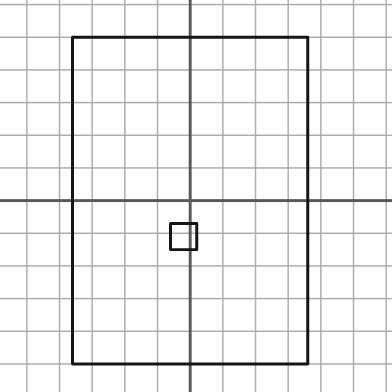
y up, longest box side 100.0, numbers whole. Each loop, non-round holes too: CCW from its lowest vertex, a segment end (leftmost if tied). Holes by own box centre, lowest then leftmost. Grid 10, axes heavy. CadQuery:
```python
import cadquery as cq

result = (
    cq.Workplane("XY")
    .moveTo(-36.0, -50.0)
    .lineTo(36.0, -50.0)
    .lineTo(36.0, 50.0)
    .lineTo(-36.0, 50.0)
    .close()
    .moveTo(-6.0, -15.0)
    .lineTo(2.0, -15.0)
    .lineTo(2.0, -7.0)
    .lineTo(-6.0, -7.0)
    .close()
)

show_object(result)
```